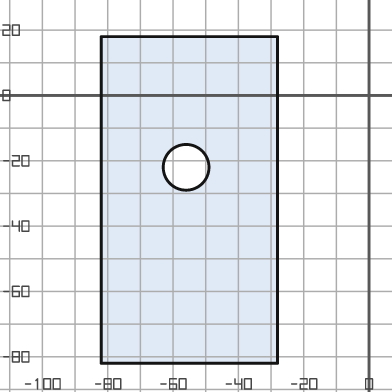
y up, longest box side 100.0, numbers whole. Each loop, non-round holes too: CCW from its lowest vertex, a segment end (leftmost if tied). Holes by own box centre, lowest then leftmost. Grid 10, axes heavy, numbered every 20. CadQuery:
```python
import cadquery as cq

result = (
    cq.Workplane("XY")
    .moveTo(-82.0, -82.0)
    .lineTo(-28.0, -82.0)
    .lineTo(-28.0, 18.0)
    .lineTo(-82.0, 18.0)
    .close()
    .moveTo(-56.0, -22.0)
    .circle(7.0)
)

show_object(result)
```